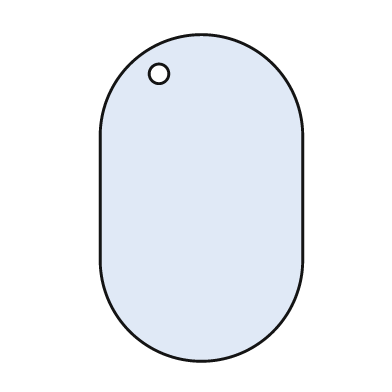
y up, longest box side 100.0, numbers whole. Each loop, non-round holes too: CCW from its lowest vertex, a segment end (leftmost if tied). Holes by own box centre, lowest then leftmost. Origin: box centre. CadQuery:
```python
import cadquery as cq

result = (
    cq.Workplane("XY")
    .moveTo(-31.0, -19.0)
    .threePointArc((0.0, -50.0), (31.0, -19.0))
    .lineTo(31.0, 19.0)
    .threePointArc((0.0, 50.0), (-31.0, 19.0))
    .close()
    .moveTo(-13.0, 38.0)
    .circle(3.0)
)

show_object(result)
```